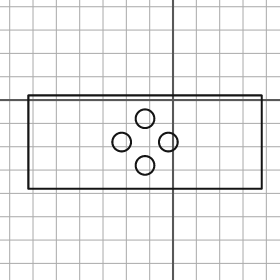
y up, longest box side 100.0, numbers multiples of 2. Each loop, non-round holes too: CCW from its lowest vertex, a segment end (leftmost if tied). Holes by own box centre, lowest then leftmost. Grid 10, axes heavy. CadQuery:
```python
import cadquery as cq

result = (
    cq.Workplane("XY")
    .moveTo(-62.0, -38.0)
    .lineTo(38.0, -38.0)
    .lineTo(38.0, 2.0)
    .lineTo(-62.0, 2.0)
    .close()
    .moveTo(-12.0, -28.0)
    .circle(4.0)
    .moveTo(-22.0, -18.0)
    .circle(4.0)
    .moveTo(-2.0, -18.0)
    .circle(4.0)
    .moveTo(-12.0, -8.0)
    .circle(4.0)
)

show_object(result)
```